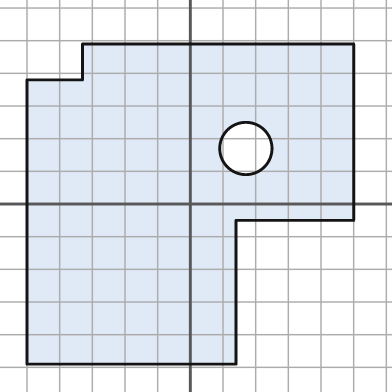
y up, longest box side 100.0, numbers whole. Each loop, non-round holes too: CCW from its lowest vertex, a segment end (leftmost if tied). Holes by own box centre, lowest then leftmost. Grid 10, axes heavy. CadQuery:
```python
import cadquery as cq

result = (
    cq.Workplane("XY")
    .moveTo(-50.0, -49.0)
    .lineTo(14.0, -49.0)
    .lineTo(14.0, -5.0)
    .lineTo(50.0, -5.0)
    .lineTo(50.0, 49.0)
    .lineTo(-33.0, 49.0)
    .lineTo(-33.0, 38.0)
    .lineTo(-50.0, 38.0)
    .close()
    .moveTo(17.0, 17.0)
    .circle(8.0)
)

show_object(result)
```